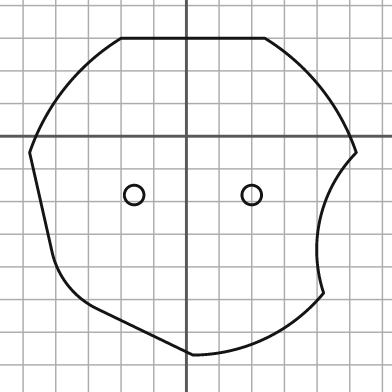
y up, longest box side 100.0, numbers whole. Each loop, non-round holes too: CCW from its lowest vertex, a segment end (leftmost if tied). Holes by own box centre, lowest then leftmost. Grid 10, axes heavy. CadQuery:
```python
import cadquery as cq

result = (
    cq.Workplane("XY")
    .moveTo(2.0, -67.0)
    .threePointArc((24.0, -62.0), (42.0, -48.0))
    .threePointArc((41.0, -25.0), (52.0, -5.0))
    .threePointArc((41.0, 15.0), (24.0, 30.0))
    .lineTo(-20.0, 30.0)
    .threePointArc((-37.0, 15.0), (-48.0, -5.0))
    .lineTo(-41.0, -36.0)
    .threePointArc((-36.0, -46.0), (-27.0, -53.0))
    .close()
    .moveTo(-16.0, -18.0)
    .circle(3.0)
    .moveTo(20.0, -18.0)
    .circle(3.0)
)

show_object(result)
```